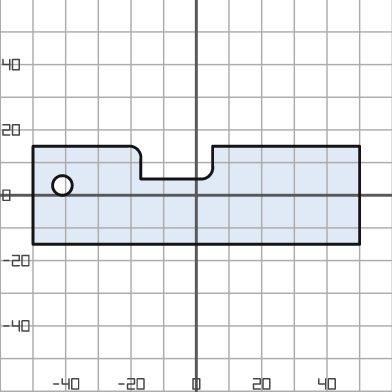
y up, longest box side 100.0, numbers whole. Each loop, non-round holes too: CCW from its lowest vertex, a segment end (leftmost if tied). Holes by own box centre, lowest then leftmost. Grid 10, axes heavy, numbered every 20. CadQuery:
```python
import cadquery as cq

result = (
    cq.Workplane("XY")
    .moveTo(-50.0, -15.0)
    .lineTo(50.0, -15.0)
    .lineTo(50.0, 15.0)
    .lineTo(5.0, 15.0)
    .lineTo(5.0, 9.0)
    .threePointArc((4.0, 6.0), (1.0, 5.0))
    .lineTo(-17.0, 5.0)
    .lineTo(-17.0, 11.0)
    .threePointArc((-18.0, 14.0), (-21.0, 15.0))
    .lineTo(-50.0, 15.0)
    .close()
    .moveTo(-41.0, 3.0)
    .circle(3.0)
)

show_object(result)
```